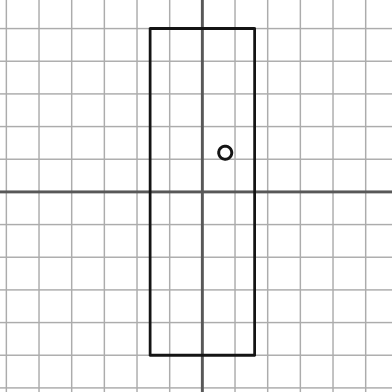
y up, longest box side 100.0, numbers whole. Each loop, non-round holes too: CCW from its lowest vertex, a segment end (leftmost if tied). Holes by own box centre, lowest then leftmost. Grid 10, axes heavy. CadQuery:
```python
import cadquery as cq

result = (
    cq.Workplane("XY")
    .moveTo(-16.0, -50.0)
    .lineTo(16.0, -50.0)
    .lineTo(16.0, 50.0)
    .lineTo(-16.0, 50.0)
    .close()
    .moveTo(7.0, 12.0)
    .circle(2.0)
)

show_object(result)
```